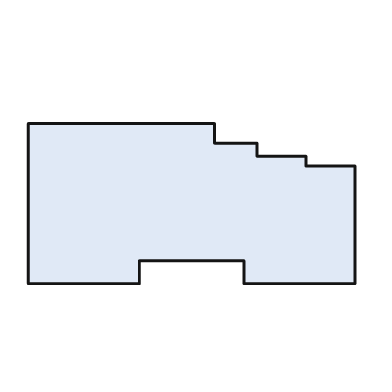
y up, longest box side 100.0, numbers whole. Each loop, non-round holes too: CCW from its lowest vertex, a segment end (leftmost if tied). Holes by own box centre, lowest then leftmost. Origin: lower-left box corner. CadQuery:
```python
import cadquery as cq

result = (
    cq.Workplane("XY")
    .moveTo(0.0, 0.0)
    .lineTo(34.0, 0.0)
    .lineTo(34.0, 7.0)
    .lineTo(66.0, 7.0)
    .lineTo(66.0, 0.0)
    .lineTo(100.0, 0.0)
    .lineTo(100.0, 36.0)
    .lineTo(85.0, 36.0)
    .lineTo(85.0, 39.0)
    .lineTo(70.0, 39.0)
    .lineTo(70.0, 43.0)
    .lineTo(57.0, 43.0)
    .lineTo(57.0, 49.0)
    .lineTo(0.0, 49.0)
    .close()
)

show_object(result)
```